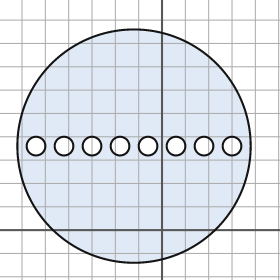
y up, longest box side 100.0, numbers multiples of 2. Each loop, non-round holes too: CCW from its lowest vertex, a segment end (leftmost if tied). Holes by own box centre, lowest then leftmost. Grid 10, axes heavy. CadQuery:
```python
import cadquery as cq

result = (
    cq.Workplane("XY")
    .moveTo(-12.0, 36.0)
    .circle(50.0)
    .moveTo(-54.0, 36.0)
    .circle(4.0)
    .moveTo(-42.0, 36.0)
    .circle(4.0)
    .moveTo(-30.0, 36.0)
    .circle(4.0)
    .moveTo(-18.0, 36.0)
    .circle(4.0)
    .moveTo(-6.0, 36.0)
    .circle(4.0)
    .moveTo(6.0, 36.0)
    .circle(4.0)
    .moveTo(18.0, 36.0)
    .circle(4.0)
    .moveTo(30.0, 36.0)
    .circle(4.0)
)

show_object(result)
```